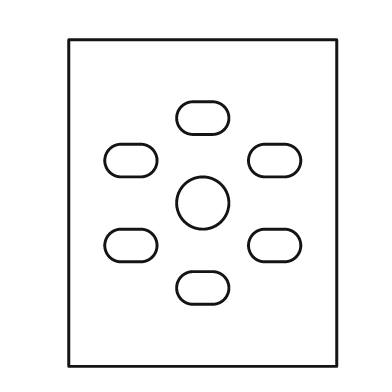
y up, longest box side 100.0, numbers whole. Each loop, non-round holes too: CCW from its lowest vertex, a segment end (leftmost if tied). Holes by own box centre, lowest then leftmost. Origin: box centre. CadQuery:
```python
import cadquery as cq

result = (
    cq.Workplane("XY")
    .moveTo(-41.0, -50.0)
    .lineTo(41.0, -50.0)
    .lineTo(41.0, 50.0)
    .lineTo(-41.0, 50.0)
    .close()
    .moveTo(-3.0, -31.0)
    .lineTo(3.0, -31.0)
    .threePointArc((8.0, -26.0), (3.0, -21.0))
    .lineTo(-3.0, -21.0)
    .threePointArc((-8.0, -26.0), (-3.0, -31.0))
    .close()
    .moveTo(-25.0, -18.0)
    .lineTo(-19.0, -18.0)
    .threePointArc((-14.0, -13.0), (-19.0, -8.0))
    .lineTo(-25.0, -8.0)
    .threePointArc((-30.0, -13.0), (-25.0, -18.0))
    .close()
    .moveTo(19.0, -18.0)
    .lineTo(25.0, -18.0)
    .threePointArc((30.0, -13.0), (25.0, -8.0))
    .lineTo(19.0, -8.0)
    .threePointArc((14.0, -13.0), (19.0, -18.0))
    .close()
    .moveTo(0.0, 0.0)
    .circle(8.0)
    .moveTo(-25.0, 8.0)
    .lineTo(-19.0, 8.0)
    .threePointArc((-14.0, 13.0), (-19.0, 18.0))
    .lineTo(-25.0, 18.0)
    .threePointArc((-30.0, 13.0), (-25.0, 8.0))
    .close()
    .moveTo(19.0, 8.0)
    .lineTo(25.0, 8.0)
    .threePointArc((30.0, 13.0), (25.0, 18.0))
    .lineTo(19.0, 18.0)
    .threePointArc((14.0, 13.0), (19.0, 8.0))
    .close()
    .moveTo(-3.0, 21.0)
    .lineTo(3.0, 21.0)
    .threePointArc((8.0, 26.0), (3.0, 31.0))
    .lineTo(-3.0, 31.0)
    .threePointArc((-8.0, 26.0), (-3.0, 21.0))
    .close()
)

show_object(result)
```